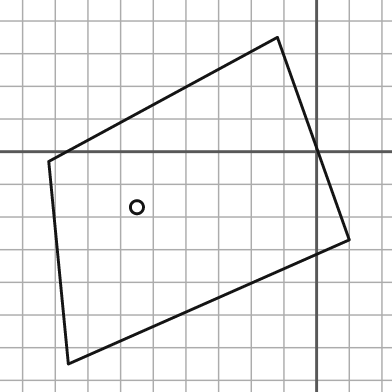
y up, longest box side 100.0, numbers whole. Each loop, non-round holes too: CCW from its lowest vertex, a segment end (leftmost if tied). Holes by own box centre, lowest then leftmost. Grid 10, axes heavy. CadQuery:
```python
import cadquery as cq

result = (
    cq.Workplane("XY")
    .moveTo(-76.0, -65.0)
    .lineTo(10.0, -27.0)
    .lineTo(-12.0, 35.0)
    .lineTo(-82.0, -3.0)
    .close()
    .moveTo(-55.0, -17.0)
    .circle(2.0)
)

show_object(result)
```